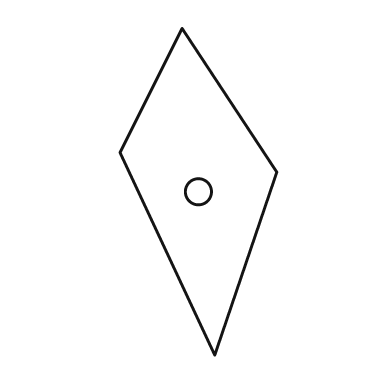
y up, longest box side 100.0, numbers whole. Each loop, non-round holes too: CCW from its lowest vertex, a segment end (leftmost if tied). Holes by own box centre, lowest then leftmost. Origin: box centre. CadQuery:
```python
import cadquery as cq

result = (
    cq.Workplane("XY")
    .moveTo(5.0, -50.0)
    .lineTo(24.0, 6.0)
    .lineTo(-5.0, 50.0)
    .lineTo(-24.0, 12.0)
    .close()
    .moveTo(0.0, 0.0)
    .circle(4.0)
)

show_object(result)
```